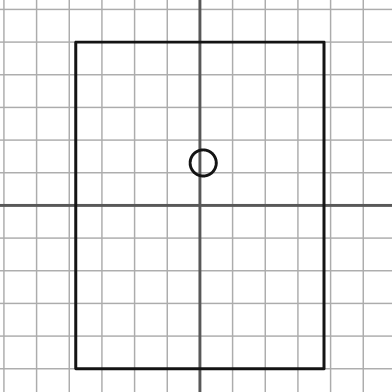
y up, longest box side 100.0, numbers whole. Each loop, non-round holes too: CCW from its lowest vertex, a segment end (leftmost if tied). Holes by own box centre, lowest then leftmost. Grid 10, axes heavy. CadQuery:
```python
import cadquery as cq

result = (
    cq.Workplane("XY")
    .moveTo(-38.0, -50.0)
    .lineTo(38.0, -50.0)
    .lineTo(38.0, 50.0)
    .lineTo(-38.0, 50.0)
    .close()
    .moveTo(1.0, 13.0)
    .circle(4.0)
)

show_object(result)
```